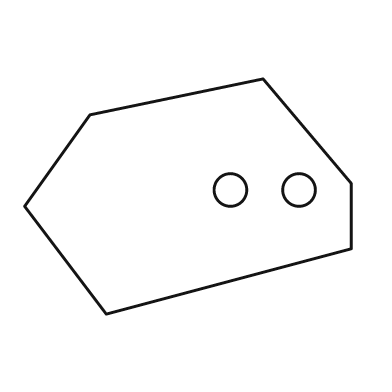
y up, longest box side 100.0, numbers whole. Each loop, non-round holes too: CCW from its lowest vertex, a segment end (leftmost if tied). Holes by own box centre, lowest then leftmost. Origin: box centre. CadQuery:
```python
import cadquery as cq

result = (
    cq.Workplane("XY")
    .moveTo(-25.0, -36.0)
    .lineTo(50.0, -16.0)
    .lineTo(50.0, 4.0)
    .lineTo(23.0, 36.0)
    .lineTo(-30.0, 25.0)
    .lineTo(-50.0, -3.0)
    .close()
    .moveTo(13.0, 2.0)
    .circle(5.0)
    .moveTo(34.0, 2.0)
    .circle(5.0)
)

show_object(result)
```